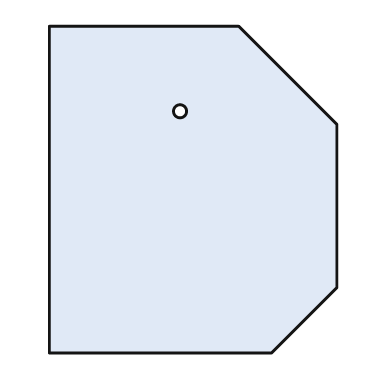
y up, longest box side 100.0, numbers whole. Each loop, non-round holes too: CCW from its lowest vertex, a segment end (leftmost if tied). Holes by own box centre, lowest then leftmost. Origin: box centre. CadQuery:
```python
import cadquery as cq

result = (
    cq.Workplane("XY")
    .moveTo(-44.0, -50.0)
    .lineTo(24.0, -50.0)
    .lineTo(44.0, -30.0)
    .lineTo(44.0, 20.0)
    .lineTo(14.0, 50.0)
    .lineTo(-44.0, 50.0)
    .close()
    .moveTo(-4.0, 24.0)
    .circle(2.0)
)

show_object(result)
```